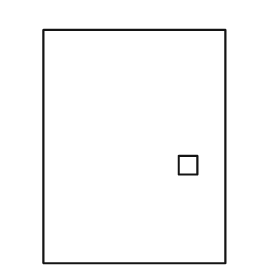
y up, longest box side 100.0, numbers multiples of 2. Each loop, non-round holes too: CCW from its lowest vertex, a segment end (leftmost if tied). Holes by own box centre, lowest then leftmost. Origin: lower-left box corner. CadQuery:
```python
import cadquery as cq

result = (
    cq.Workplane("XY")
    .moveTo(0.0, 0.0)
    .lineTo(78.0, 0.0)
    .lineTo(78.0, 100.0)
    .lineTo(0.0, 100.0)
    .close()
    .moveTo(58.0, 38.0)
    .lineTo(66.0, 38.0)
    .lineTo(66.0, 46.0)
    .lineTo(58.0, 46.0)
    .close()
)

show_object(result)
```